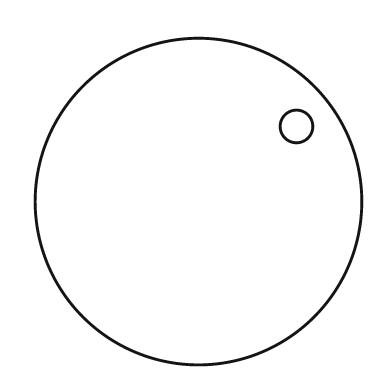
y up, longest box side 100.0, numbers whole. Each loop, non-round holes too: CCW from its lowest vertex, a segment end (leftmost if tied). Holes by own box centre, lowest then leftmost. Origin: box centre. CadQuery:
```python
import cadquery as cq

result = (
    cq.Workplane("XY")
    .moveTo(0.0, 0.0)
    .circle(50.0)
    .moveTo(30.0, 23.0)
    .circle(5.0)
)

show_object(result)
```